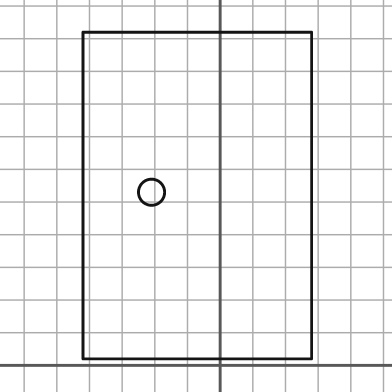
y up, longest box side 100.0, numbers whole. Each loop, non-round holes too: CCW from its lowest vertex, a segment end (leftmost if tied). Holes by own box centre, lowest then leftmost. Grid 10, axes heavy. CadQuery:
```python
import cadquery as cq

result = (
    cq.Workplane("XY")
    .moveTo(-42.0, 2.0)
    .lineTo(28.0, 2.0)
    .lineTo(28.0, 102.0)
    .lineTo(-42.0, 102.0)
    .close()
    .moveTo(-21.0, 53.0)
    .circle(4.0)
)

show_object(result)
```